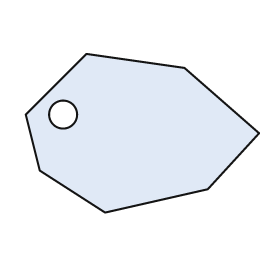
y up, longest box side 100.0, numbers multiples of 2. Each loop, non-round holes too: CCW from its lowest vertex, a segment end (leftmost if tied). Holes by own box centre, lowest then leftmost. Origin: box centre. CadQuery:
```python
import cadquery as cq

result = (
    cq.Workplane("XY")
    .moveTo(-16.0, -34.0)
    .lineTo(28.0, -24.0)
    .lineTo(50.0, 0.0)
    .lineTo(18.0, 28.0)
    .lineTo(-24.0, 34.0)
    .lineTo(-50.0, 8.0)
    .lineTo(-44.0, -16.0)
    .close()
    .moveTo(-34.0, 8.0)
    .circle(6.0)
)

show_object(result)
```